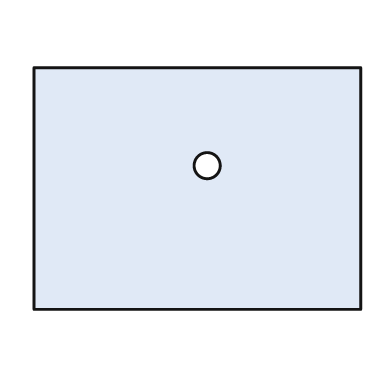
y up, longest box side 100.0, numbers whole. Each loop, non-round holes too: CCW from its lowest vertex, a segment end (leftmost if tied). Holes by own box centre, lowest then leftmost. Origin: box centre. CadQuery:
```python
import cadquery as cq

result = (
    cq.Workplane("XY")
    .moveTo(-50.0, -37.0)
    .lineTo(50.0, -37.0)
    .lineTo(50.0, 37.0)
    .lineTo(-50.0, 37.0)
    .close()
    .moveTo(3.0, 7.0)
    .circle(4.0)
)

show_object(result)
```